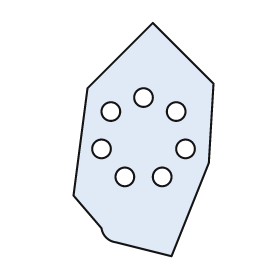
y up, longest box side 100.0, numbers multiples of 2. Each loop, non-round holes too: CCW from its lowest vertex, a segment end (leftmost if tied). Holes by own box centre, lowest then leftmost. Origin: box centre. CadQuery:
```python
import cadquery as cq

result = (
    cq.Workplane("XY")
    .moveTo(12.0, -50.0)
    .lineTo(28.0, -10.0)
    .lineTo(30.0, 24.0)
    .lineTo(4.0, 50.0)
    .lineTo(-24.0, 22.0)
    .lineTo(-30.0, -24.0)
    .lineTo(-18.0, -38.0)
    .threePointArc((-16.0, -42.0), (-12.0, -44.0))
    .close()
    .moveTo(-8.0, -16.0)
    .circle(4.0)
    .moveTo(8.0, -16.0)
    .circle(4.0)
    .moveTo(-18.0, -4.0)
    .circle(4.0)
    .moveTo(18.0, -4.0)
    .circle(4.0)
    .moveTo(-14.0, 12.0)
    .circle(4.0)
    .moveTo(14.0, 12.0)
    .circle(4.0)
    .moveTo(0.0, 18.0)
    .circle(4.0)
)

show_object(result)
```